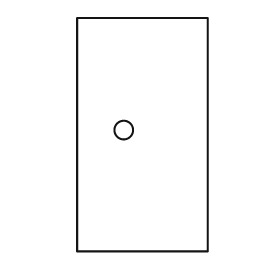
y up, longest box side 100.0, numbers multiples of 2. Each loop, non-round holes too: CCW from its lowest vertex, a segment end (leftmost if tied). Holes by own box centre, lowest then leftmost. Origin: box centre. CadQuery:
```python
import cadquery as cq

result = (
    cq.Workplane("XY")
    .moveTo(-28.0, -50.0)
    .lineTo(28.0, -50.0)
    .lineTo(28.0, 50.0)
    .lineTo(-28.0, 50.0)
    .close()
    .moveTo(-8.0, 2.0)
    .circle(4.0)
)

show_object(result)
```